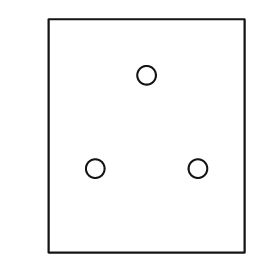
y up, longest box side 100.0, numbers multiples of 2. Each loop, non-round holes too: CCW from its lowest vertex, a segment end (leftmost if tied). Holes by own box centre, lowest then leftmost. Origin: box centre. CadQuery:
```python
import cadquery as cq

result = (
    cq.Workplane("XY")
    .moveTo(-42.0, -50.0)
    .lineTo(42.0, -50.0)
    .lineTo(42.0, 50.0)
    .lineTo(-42.0, 50.0)
    .close()
    .moveTo(-22.0, -14.0)
    .circle(4.0)
    .moveTo(22.0, -14.0)
    .circle(4.0)
    .moveTo(0.0, 26.0)
    .circle(4.0)
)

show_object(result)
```